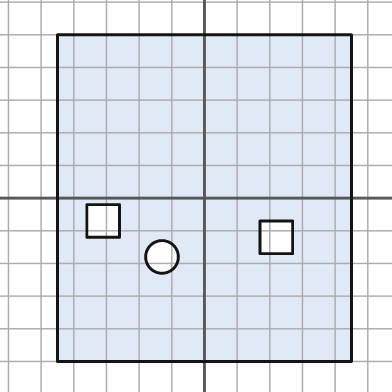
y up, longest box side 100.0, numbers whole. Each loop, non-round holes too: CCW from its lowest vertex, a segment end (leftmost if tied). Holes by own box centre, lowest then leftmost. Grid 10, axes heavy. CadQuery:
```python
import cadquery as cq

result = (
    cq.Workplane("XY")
    .moveTo(-45.0, -50.0)
    .lineTo(45.0, -50.0)
    .lineTo(45.0, 50.0)
    .lineTo(-45.0, 50.0)
    .close()
    .moveTo(-13.0, -18.0)
    .circle(5.0)
    .moveTo(17.0, -17.0)
    .lineTo(27.0, -17.0)
    .lineTo(27.0, -7.0)
    .lineTo(17.0, -7.0)
    .close()
    .moveTo(-36.0, -12.0)
    .lineTo(-26.0, -12.0)
    .lineTo(-26.0, -2.0)
    .lineTo(-36.0, -2.0)
    .close()
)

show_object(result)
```